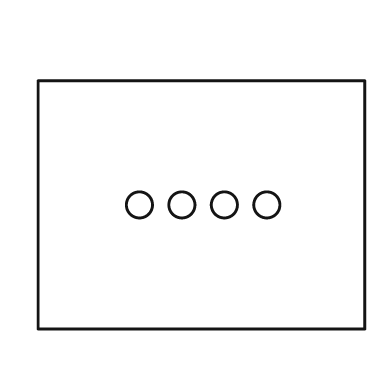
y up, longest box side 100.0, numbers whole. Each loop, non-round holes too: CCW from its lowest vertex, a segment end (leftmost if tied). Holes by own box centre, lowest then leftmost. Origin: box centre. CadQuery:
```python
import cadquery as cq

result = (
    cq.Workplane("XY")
    .moveTo(-50.0, -38.0)
    .lineTo(50.0, -38.0)
    .lineTo(50.0, 38.0)
    .lineTo(-50.0, 38.0)
    .close()
    .moveTo(-19.0, 0.0)
    .circle(4.0)
    .moveTo(-6.0, 0.0)
    .circle(4.0)
    .moveTo(7.0, 0.0)
    .circle(4.0)
    .moveTo(20.0, 0.0)
    .circle(4.0)
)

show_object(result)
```